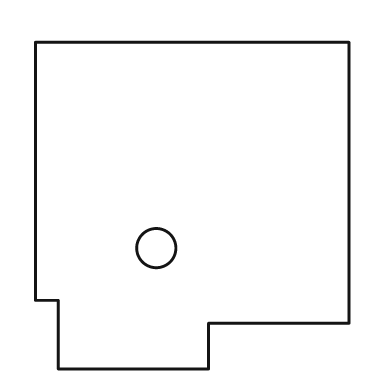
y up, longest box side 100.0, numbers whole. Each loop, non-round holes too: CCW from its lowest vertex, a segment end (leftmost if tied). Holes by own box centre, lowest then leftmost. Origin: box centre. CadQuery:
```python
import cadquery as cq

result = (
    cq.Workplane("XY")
    .moveTo(-41.0, -50.0)
    .lineTo(5.0, -50.0)
    .lineTo(5.0, -36.0)
    .lineTo(48.0, -36.0)
    .lineTo(48.0, 50.0)
    .lineTo(-48.0, 50.0)
    .lineTo(-48.0, -29.0)
    .lineTo(-41.0, -29.0)
    .close()
    .moveTo(-11.0, -13.0)
    .circle(6.0)
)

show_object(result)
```